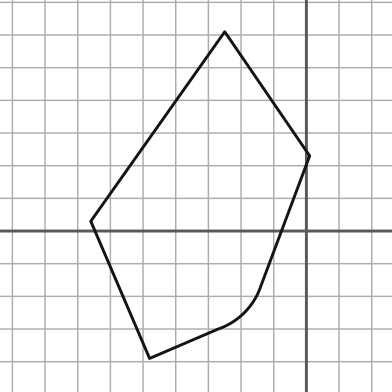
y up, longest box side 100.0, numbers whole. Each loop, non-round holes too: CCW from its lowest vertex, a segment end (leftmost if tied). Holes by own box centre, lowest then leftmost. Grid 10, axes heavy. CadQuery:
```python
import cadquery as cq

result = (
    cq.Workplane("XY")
    .moveTo(-48.0, -39.0)
    .lineTo(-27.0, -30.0)
    .threePointArc((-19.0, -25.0), (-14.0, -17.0))
    .lineTo(1.0, 23.0)
    .lineTo(-25.0, 61.0)
    .lineTo(-66.0, 3.0)
    .close()
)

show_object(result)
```